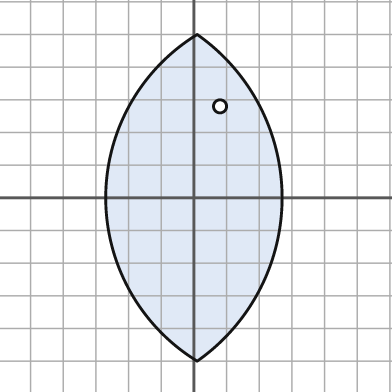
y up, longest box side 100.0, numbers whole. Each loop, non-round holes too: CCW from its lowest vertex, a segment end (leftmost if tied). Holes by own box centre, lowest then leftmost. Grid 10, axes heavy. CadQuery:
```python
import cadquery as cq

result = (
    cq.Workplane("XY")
    .moveTo(1.0, -50.0)
    .threePointArc((27.0, 0.0), (1.0, 50.0))
    .threePointArc((-27.0, 0.0), (1.0, -50.0))
    .close()
    .moveTo(8.0, 28.0)
    .circle(2.0)
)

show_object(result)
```